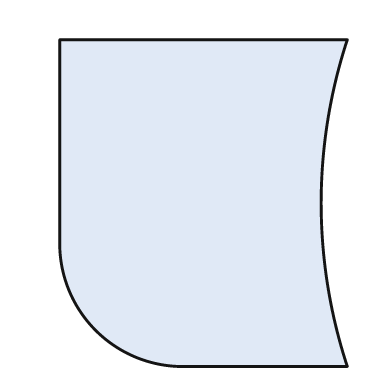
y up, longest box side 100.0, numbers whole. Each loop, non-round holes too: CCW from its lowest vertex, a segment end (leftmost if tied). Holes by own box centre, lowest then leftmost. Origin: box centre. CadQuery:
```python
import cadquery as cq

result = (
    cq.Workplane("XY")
    .moveTo(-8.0, -50.0)
    .lineTo(44.0, -50.0)
    .threePointArc((36.0, 0.0), (44.0, 50.0))
    .lineTo(-44.0, 50.0)
    .lineTo(-44.0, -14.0)
    .threePointArc((-33.0, -39.0), (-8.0, -50.0))
    .close()
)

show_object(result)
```